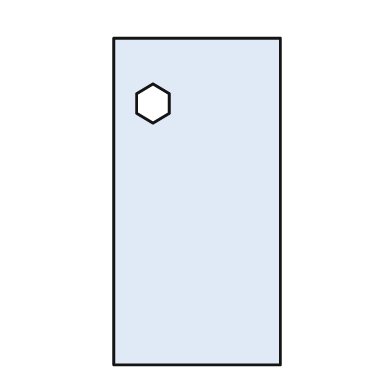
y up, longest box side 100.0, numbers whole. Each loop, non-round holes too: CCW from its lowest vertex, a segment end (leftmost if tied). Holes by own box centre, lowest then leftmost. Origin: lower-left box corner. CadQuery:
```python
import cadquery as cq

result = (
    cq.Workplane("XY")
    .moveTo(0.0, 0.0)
    .lineTo(51.0, 0.0)
    .lineTo(51.0, 100.0)
    .lineTo(0.0, 100.0)
    .close()
    .moveTo(12.0, 74.0)
    .lineTo(17.0, 77.0)
    .lineTo(17.0, 83.0)
    .lineTo(12.0, 86.0)
    .lineTo(7.0, 83.0)
    .lineTo(7.0, 77.0)
    .close()
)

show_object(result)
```